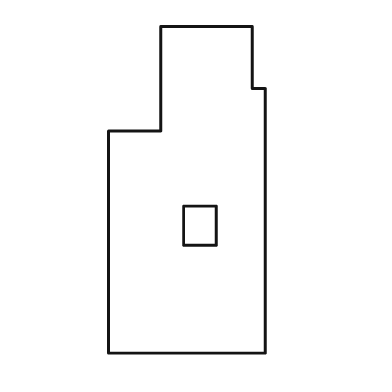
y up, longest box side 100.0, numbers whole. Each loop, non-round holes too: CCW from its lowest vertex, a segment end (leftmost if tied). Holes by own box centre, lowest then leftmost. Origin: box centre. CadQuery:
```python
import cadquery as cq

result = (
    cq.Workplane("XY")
    .moveTo(-24.0, -50.0)
    .lineTo(24.0, -50.0)
    .lineTo(24.0, 31.0)
    .lineTo(20.0, 31.0)
    .lineTo(20.0, 50.0)
    .lineTo(-8.0, 50.0)
    .lineTo(-8.0, 18.0)
    .lineTo(-24.0, 18.0)
    .close()
    .moveTo(-1.0, -17.0)
    .lineTo(9.0, -17.0)
    .lineTo(9.0, -5.0)
    .lineTo(-1.0, -5.0)
    .close()
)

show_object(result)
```